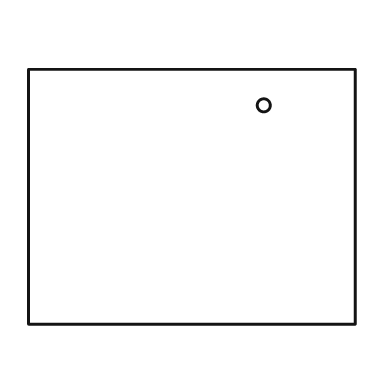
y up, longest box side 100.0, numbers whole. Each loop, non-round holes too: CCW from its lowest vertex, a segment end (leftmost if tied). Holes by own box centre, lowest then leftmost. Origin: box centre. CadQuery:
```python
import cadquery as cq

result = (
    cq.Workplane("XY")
    .moveTo(-50.0, -39.0)
    .lineTo(50.0, -39.0)
    .lineTo(50.0, 39.0)
    .lineTo(-50.0, 39.0)
    .close()
    .moveTo(22.0, 28.0)
    .circle(2.0)
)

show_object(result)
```